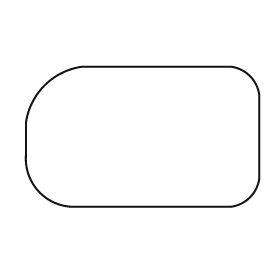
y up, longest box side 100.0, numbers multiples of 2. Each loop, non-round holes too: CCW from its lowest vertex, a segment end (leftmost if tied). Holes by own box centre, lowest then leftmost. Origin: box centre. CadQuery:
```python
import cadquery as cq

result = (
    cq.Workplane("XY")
    .moveTo(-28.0, -30.0)
    .lineTo(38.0, -30.0)
    .threePointArc((46.0, -26.0), (50.0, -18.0))
    .lineTo(50.0, 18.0)
    .threePointArc((46.0, 26.0), (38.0, 30.0))
    .lineTo(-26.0, 30.0)
    .threePointArc((-42.0, 22.0), (-50.0, 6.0))
    .lineTo(-50.0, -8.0)
    .threePointArc((-44.0, -24.0), (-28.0, -30.0))
    .close()
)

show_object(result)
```